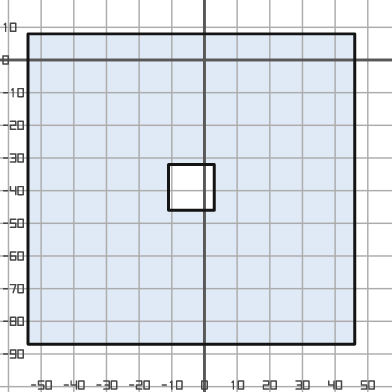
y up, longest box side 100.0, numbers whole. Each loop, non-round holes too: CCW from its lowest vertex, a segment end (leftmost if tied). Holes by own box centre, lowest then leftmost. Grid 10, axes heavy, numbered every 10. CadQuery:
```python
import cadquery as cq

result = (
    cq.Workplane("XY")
    .moveTo(-54.0, -87.0)
    .lineTo(46.0, -87.0)
    .lineTo(46.0, 8.0)
    .lineTo(-54.0, 8.0)
    .close()
    .moveTo(-11.0, -46.0)
    .lineTo(3.0, -46.0)
    .lineTo(3.0, -32.0)
    .lineTo(-11.0, -32.0)
    .close()
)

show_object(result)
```